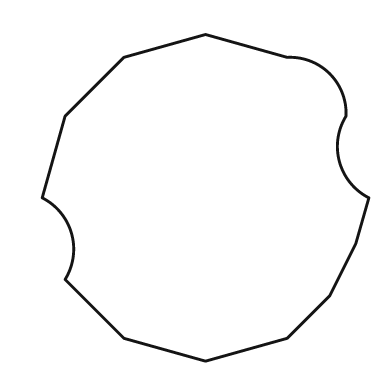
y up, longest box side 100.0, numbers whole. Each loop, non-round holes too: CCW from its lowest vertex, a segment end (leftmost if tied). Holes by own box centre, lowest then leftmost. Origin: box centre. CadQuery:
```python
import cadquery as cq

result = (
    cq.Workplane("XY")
    .moveTo(0.0, -50.0)
    .lineTo(25.0, -43.0)
    .lineTo(38.0, -30.0)
    .lineTo(46.0, -14.0)
    .lineTo(50.0, 0.0)
    .threePointArc((41.0, 11.0), (43.0, 25.0))
    .threePointArc((38.0, 38.0), (25.0, 43.0))
    .lineTo(0.0, 50.0)
    .lineTo(-25.0, 43.0)
    .lineTo(-43.0, 25.0)
    .lineTo(-50.0, 0.0)
    .threePointArc((-41.0, -11.0), (-43.0, -25.0))
    .lineTo(-25.0, -43.0)
    .close()
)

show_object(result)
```